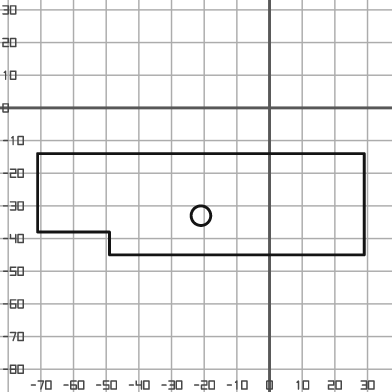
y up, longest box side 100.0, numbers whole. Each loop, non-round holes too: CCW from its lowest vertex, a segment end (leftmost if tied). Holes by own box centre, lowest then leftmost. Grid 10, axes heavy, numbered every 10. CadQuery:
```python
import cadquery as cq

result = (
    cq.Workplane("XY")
    .moveTo(-49.0, -45.0)
    .lineTo(29.0, -45.0)
    .lineTo(29.0, -14.0)
    .lineTo(-71.0, -14.0)
    .lineTo(-71.0, -38.0)
    .lineTo(-49.0, -38.0)
    .close()
    .moveTo(-21.0, -33.0)
    .circle(3.0)
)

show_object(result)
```